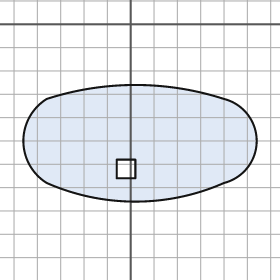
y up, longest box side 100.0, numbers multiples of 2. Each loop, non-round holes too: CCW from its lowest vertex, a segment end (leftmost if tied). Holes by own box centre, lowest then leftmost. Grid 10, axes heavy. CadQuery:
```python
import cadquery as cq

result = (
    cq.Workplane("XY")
    .moveTo(-36.0, -68.0)
    .threePointArc((2.0, -76.0), (40.0, -68.0))
    .threePointArc((54.0, -50.0), (40.0, -32.0))
    .threePointArc((2.0, -26.0), (-36.0, -32.0))
    .threePointArc((-46.0, -50.0), (-36.0, -68.0))
    .close()
    .moveTo(-6.0, -66.0)
    .lineTo(2.0, -66.0)
    .lineTo(2.0, -58.0)
    .lineTo(-6.0, -58.0)
    .close()
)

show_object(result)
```